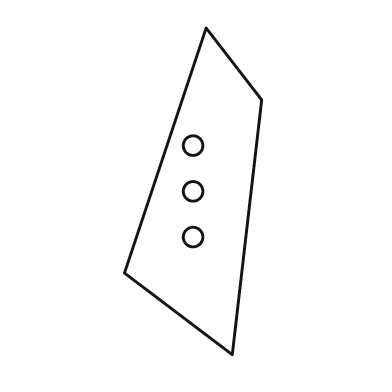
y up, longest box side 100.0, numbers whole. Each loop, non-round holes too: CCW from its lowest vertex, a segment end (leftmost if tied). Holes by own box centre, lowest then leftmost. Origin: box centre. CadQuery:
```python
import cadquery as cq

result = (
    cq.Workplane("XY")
    .moveTo(12.0, -50.0)
    .lineTo(21.0, 28.0)
    .lineTo(4.0, 50.0)
    .lineTo(-21.0, -25.0)
    .close()
    .moveTo(0.0, -14.0)
    .circle(3.0)
    .moveTo(0.0, 0.0)
    .circle(3.0)
    .moveTo(0.0, 14.0)
    .circle(3.0)
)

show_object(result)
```